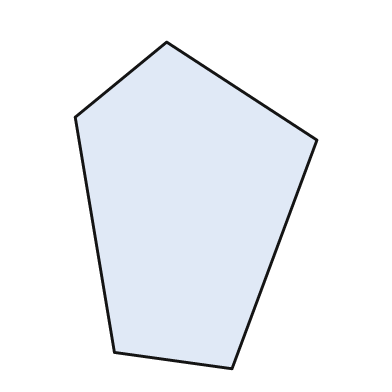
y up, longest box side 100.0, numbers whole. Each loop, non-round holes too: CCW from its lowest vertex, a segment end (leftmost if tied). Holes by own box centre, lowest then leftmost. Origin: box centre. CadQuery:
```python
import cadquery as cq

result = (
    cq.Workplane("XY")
    .moveTo(11.0, -50.0)
    .lineTo(37.0, 20.0)
    .lineTo(-9.0, 50.0)
    .lineTo(-37.0, 27.0)
    .lineTo(-25.0, -45.0)
    .close()
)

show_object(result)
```